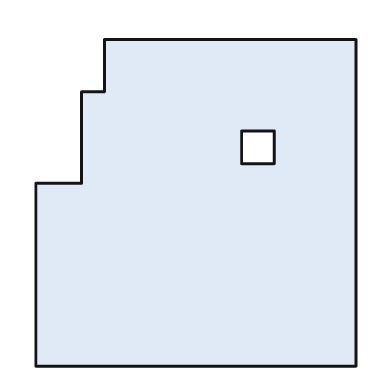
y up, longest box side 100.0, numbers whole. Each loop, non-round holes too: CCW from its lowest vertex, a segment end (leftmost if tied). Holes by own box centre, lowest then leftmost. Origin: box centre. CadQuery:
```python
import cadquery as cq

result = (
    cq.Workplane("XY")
    .moveTo(-49.0, -50.0)
    .lineTo(49.0, -50.0)
    .lineTo(49.0, 50.0)
    .lineTo(-28.0, 50.0)
    .lineTo(-28.0, 34.0)
    .lineTo(-35.0, 34.0)
    .lineTo(-35.0, 6.0)
    .lineTo(-49.0, 6.0)
    .close()
    .moveTo(14.0, 12.0)
    .lineTo(24.0, 12.0)
    .lineTo(24.0, 22.0)
    .lineTo(14.0, 22.0)
    .close()
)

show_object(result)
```